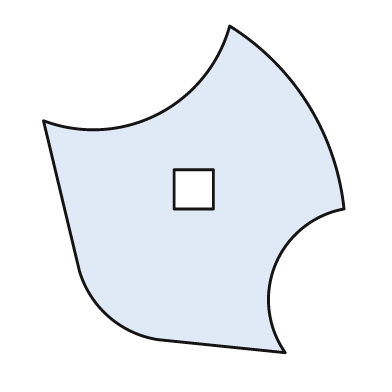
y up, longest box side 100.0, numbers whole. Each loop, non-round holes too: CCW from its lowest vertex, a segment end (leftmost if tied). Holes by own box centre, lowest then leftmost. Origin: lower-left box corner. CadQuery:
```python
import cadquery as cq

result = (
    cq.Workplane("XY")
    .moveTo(74.0, 0.0)
    .threePointArc((71.0, 27.0), (92.0, 44.0))
    .threePointArc((81.0, 76.0), (57.0, 100.0))
    .threePointArc((35.0, 73.0), (0.0, 71.0))
    .lineTo(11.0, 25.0)
    .threePointArc((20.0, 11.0), (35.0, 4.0))
    .close()
    .moveTo(40.0, 44.0)
    .lineTo(52.0, 44.0)
    .lineTo(52.0, 56.0)
    .lineTo(40.0, 56.0)
    .close()
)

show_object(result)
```